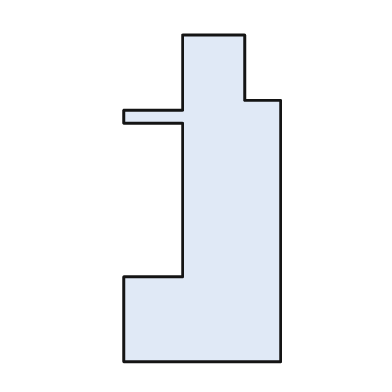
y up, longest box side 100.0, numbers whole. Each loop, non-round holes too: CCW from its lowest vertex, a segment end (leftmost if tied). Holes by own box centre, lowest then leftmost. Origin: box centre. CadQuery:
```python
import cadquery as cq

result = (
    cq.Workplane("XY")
    .moveTo(-24.0, -50.0)
    .lineTo(24.0, -50.0)
    .lineTo(24.0, 30.0)
    .lineTo(13.0, 30.0)
    .lineTo(13.0, 50.0)
    .lineTo(-6.0, 50.0)
    .lineTo(-6.0, 27.0)
    .lineTo(-24.0, 27.0)
    .lineTo(-24.0, 23.0)
    .lineTo(-6.0, 23.0)
    .lineTo(-6.0, -24.0)
    .lineTo(-24.0, -24.0)
    .close()
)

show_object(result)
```